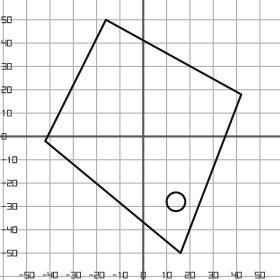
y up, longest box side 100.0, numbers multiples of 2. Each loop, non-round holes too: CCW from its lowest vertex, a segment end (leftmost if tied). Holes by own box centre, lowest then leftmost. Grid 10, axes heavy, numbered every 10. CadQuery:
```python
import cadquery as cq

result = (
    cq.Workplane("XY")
    .moveTo(16.0, -50.0)
    .lineTo(42.0, 18.0)
    .lineTo(-16.0, 50.0)
    .lineTo(-42.0, -2.0)
    .close()
    .moveTo(14.0, -28.0)
    .circle(4.0)
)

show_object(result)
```